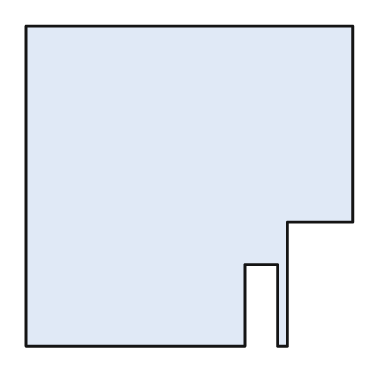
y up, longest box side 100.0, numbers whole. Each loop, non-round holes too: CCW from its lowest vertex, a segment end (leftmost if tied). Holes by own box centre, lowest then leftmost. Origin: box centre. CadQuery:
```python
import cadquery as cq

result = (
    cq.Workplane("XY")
    .moveTo(-50.0, -49.0)
    .lineTo(17.0, -49.0)
    .lineTo(17.0, -24.0)
    .lineTo(27.0, -24.0)
    .lineTo(27.0, -49.0)
    .lineTo(30.0, -49.0)
    .lineTo(30.0, -11.0)
    .lineTo(50.0, -11.0)
    .lineTo(50.0, 49.0)
    .lineTo(-50.0, 49.0)
    .close()
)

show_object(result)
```